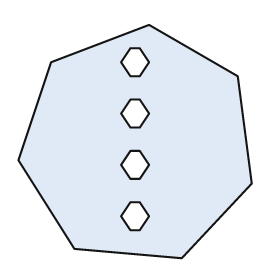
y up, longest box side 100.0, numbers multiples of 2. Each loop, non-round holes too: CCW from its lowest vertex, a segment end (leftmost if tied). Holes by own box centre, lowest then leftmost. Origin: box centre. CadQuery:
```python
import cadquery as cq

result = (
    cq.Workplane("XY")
    .moveTo(20.0, -50.0)
    .lineTo(50.0, -18.0)
    .lineTo(44.0, 28.0)
    .lineTo(6.0, 50.0)
    .lineTo(-36.0, 34.0)
    .lineTo(-50.0, -8.0)
    .lineTo(-26.0, -46.0)
    .close()
    .moveTo(-2.0, -38.0)
    .lineTo(2.0, -38.0)
    .lineTo(6.0, -32.0)
    .lineTo(2.0, -26.0)
    .lineTo(-2.0, -26.0)
    .lineTo(-6.0, -32.0)
    .close()
    .moveTo(-2.0, -16.0)
    .lineTo(2.0, -16.0)
    .lineTo(6.0, -10.0)
    .lineTo(2.0, -4.0)
    .lineTo(-2.0, -4.0)
    .lineTo(-6.0, -10.0)
    .close()
    .moveTo(-2.0, 6.0)
    .lineTo(2.0, 6.0)
    .lineTo(6.0, 12.0)
    .lineTo(2.0, 18.0)
    .lineTo(-2.0, 18.0)
    .lineTo(-6.0, 12.0)
    .close()
    .moveTo(-2.0, 28.0)
    .lineTo(2.0, 28.0)
    .lineTo(6.0, 34.0)
    .lineTo(2.0, 40.0)
    .lineTo(-2.0, 40.0)
    .lineTo(-6.0, 34.0)
    .close()
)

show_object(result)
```